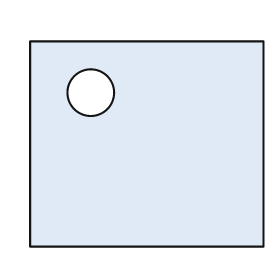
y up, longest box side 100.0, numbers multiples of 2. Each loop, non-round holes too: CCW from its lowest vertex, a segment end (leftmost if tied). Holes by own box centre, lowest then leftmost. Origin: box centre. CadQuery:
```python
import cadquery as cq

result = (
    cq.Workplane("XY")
    .moveTo(-50.0, -44.0)
    .lineTo(50.0, -44.0)
    .lineTo(50.0, 44.0)
    .lineTo(-50.0, 44.0)
    .close()
    .moveTo(-24.0, 22.0)
    .circle(10.0)
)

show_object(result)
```